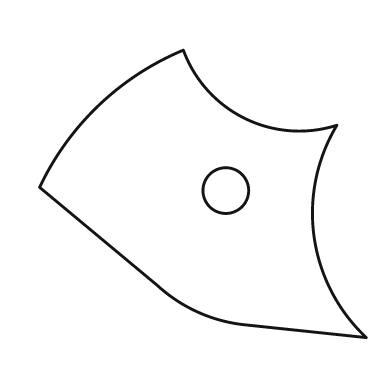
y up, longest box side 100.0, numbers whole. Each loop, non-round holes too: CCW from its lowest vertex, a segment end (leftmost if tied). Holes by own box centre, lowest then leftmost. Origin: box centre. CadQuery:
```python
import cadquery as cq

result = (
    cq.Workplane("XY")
    .moveTo(50.0, -44.0)
    .threePointArc((34.0, -13.0), (41.0, 21.0))
    .threePointArc((13.0, 23.0), (-6.0, 44.0))
    .threePointArc((-32.0, 27.0), (-50.0, 2.0))
    .lineTo(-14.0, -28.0)
    .threePointArc((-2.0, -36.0), (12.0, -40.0))
    .close()
    .moveTo(7.0, 1.0)
    .circle(7.0)
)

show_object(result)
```